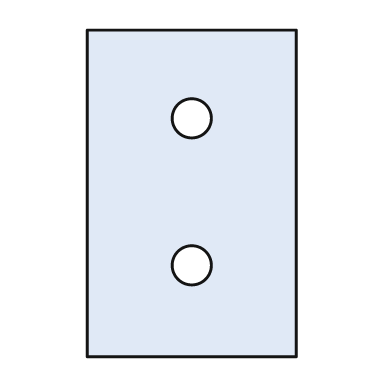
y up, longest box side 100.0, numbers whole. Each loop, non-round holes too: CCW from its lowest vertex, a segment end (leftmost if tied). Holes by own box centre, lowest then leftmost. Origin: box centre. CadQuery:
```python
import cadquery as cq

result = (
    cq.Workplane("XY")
    .moveTo(-32.0, -50.0)
    .lineTo(32.0, -50.0)
    .lineTo(32.0, 50.0)
    .lineTo(-32.0, 50.0)
    .close()
    .moveTo(0.0, -22.0)
    .circle(6.0)
    .moveTo(0.0, 23.0)
    .circle(6.0)
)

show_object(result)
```